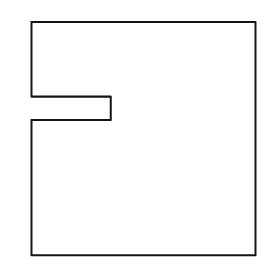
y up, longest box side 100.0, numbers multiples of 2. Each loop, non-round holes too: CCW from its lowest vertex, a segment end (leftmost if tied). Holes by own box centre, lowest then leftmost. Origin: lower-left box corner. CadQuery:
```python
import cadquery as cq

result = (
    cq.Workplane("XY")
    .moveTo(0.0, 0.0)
    .lineTo(96.0, 0.0)
    .lineTo(96.0, 100.0)
    .lineTo(0.0, 100.0)
    .lineTo(0.0, 68.0)
    .lineTo(34.0, 68.0)
    .lineTo(34.0, 58.0)
    .lineTo(0.0, 58.0)
    .close()
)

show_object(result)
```